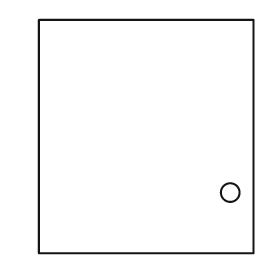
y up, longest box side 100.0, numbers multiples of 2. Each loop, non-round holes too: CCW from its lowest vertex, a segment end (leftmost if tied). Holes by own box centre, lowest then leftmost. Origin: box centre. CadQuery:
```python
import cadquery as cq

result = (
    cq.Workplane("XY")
    .moveTo(-46.0, -50.0)
    .lineTo(46.0, -50.0)
    .lineTo(46.0, 50.0)
    .lineTo(-46.0, 50.0)
    .close()
    .moveTo(36.0, -24.0)
    .circle(4.0)
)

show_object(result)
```